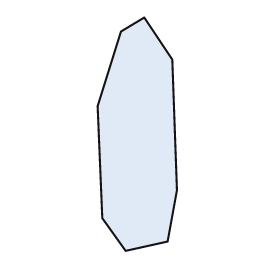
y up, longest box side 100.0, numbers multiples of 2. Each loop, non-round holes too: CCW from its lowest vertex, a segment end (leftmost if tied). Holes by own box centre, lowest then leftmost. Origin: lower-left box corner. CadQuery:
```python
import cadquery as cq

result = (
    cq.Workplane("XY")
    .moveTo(12.0, 0.0)
    .lineTo(30.0, 4.0)
    .lineTo(34.0, 26.0)
    .lineTo(32.0, 82.0)
    .lineTo(20.0, 100.0)
    .lineTo(10.0, 94.0)
    .lineTo(0.0, 62.0)
    .lineTo(2.0, 14.0)
    .close()
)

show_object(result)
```